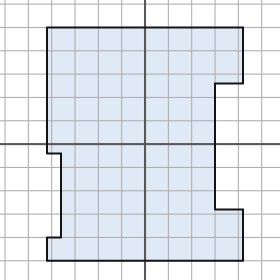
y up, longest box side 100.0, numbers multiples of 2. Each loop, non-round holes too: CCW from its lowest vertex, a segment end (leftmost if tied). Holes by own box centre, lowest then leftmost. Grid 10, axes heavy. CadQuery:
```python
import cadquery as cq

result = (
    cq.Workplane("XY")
    .moveTo(-42.0, -50.0)
    .lineTo(42.0, -50.0)
    .lineTo(42.0, -28.0)
    .lineTo(30.0, -28.0)
    .lineTo(30.0, 26.0)
    .lineTo(42.0, 26.0)
    .lineTo(42.0, 50.0)
    .lineTo(-42.0, 50.0)
    .lineTo(-42.0, -4.0)
    .lineTo(-36.0, -4.0)
    .lineTo(-36.0, -40.0)
    .lineTo(-42.0, -40.0)
    .close()
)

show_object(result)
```